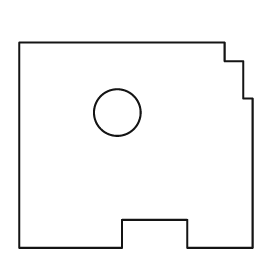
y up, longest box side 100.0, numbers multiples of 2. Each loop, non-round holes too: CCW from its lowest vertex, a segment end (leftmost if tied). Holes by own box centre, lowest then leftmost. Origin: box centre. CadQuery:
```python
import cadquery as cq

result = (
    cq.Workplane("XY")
    .moveTo(-50.0, -44.0)
    .lineTo(-6.0, -44.0)
    .lineTo(-6.0, -32.0)
    .lineTo(22.0, -32.0)
    .lineTo(22.0, -44.0)
    .lineTo(50.0, -44.0)
    .lineTo(50.0, 20.0)
    .lineTo(46.0, 20.0)
    .lineTo(46.0, 36.0)
    .lineTo(38.0, 36.0)
    .lineTo(38.0, 44.0)
    .lineTo(-50.0, 44.0)
    .close()
    .moveTo(-8.0, 14.0)
    .circle(10.0)
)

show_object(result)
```